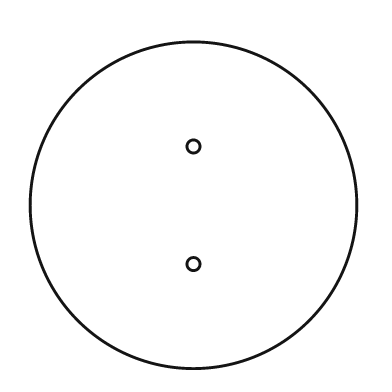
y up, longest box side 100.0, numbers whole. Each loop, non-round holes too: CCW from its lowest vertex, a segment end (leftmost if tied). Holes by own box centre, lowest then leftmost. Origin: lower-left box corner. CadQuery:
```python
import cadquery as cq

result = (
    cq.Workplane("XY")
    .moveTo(50.0, 50.0)
    .circle(50.0)
    .moveTo(50.0, 32.0)
    .circle(2.0)
    .moveTo(50.0, 68.0)
    .circle(2.0)
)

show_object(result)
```